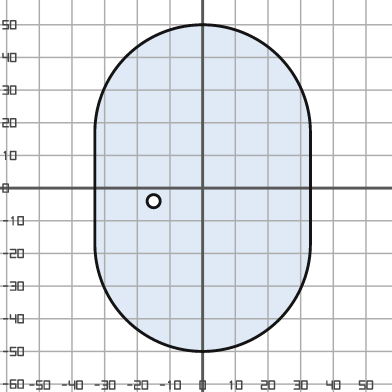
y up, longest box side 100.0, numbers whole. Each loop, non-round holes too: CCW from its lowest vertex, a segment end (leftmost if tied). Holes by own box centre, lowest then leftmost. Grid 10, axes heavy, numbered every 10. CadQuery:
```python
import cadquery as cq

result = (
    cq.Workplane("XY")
    .moveTo(-33.0, -17.0)
    .threePointArc((0.0, -50.0), (33.0, -17.0))
    .lineTo(33.0, 17.0)
    .threePointArc((0.0, 50.0), (-33.0, 17.0))
    .close()
    .moveTo(-15.0, -4.0)
    .circle(2.0)
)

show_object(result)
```